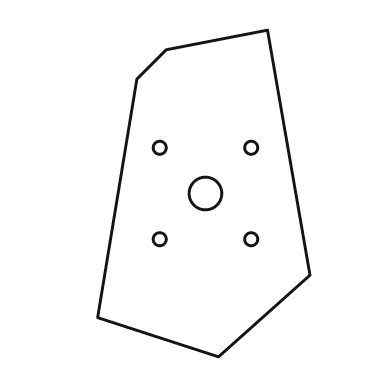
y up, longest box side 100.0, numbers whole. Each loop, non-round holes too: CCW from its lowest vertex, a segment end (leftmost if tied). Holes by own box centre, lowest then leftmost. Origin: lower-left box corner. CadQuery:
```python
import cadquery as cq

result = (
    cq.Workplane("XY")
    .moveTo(37.0, 0.0)
    .lineTo(65.0, 25.0)
    .lineTo(52.0, 100.0)
    .lineTo(21.0, 94.0)
    .lineTo(12.0, 85.0)
    .lineTo(0.0, 12.0)
    .close()
    .moveTo(19.0, 36.0)
    .circle(2.0)
    .moveTo(47.0, 36.0)
    .circle(2.0)
    .moveTo(33.0, 50.0)
    .circle(5.0)
    .moveTo(19.0, 64.0)
    .circle(2.0)
    .moveTo(47.0, 64.0)
    .circle(2.0)
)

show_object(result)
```